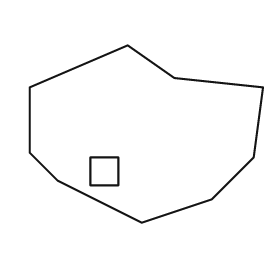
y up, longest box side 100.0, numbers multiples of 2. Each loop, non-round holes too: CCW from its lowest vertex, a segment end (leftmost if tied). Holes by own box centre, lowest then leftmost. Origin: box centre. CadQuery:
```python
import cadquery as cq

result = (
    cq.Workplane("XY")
    .moveTo(-2.0, -38.0)
    .lineTo(28.0, -28.0)
    .lineTo(46.0, -10.0)
    .lineTo(50.0, 20.0)
    .lineTo(12.0, 24.0)
    .lineTo(-8.0, 38.0)
    .lineTo(-50.0, 20.0)
    .lineTo(-50.0, -8.0)
    .lineTo(-38.0, -20.0)
    .close()
    .moveTo(-24.0, -22.0)
    .lineTo(-12.0, -22.0)
    .lineTo(-12.0, -10.0)
    .lineTo(-24.0, -10.0)
    .close()
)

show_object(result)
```